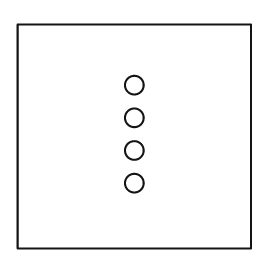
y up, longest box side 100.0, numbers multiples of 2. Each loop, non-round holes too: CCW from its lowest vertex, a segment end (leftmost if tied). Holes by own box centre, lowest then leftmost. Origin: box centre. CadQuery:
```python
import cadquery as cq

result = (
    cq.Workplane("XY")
    .moveTo(-50.0, -48.0)
    .lineTo(50.0, -48.0)
    .lineTo(50.0, 48.0)
    .lineTo(-50.0, 48.0)
    .close()
    .moveTo(0.0, -20.0)
    .circle(4.0)
    .moveTo(0.0, -6.0)
    .circle(4.0)
    .moveTo(0.0, 8.0)
    .circle(4.0)
    .moveTo(0.0, 22.0)
    .circle(4.0)
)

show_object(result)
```